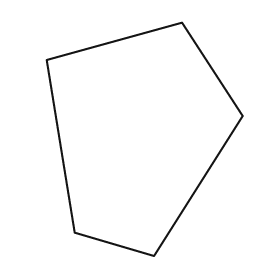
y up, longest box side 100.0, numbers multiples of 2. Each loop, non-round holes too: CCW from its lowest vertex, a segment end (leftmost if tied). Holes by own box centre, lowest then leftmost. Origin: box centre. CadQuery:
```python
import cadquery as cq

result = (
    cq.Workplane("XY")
    .moveTo(4.0, -50.0)
    .lineTo(42.0, 10.0)
    .lineTo(16.0, 50.0)
    .lineTo(-42.0, 34.0)
    .lineTo(-30.0, -40.0)
    .close()
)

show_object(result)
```